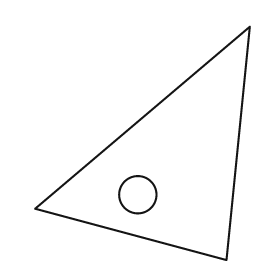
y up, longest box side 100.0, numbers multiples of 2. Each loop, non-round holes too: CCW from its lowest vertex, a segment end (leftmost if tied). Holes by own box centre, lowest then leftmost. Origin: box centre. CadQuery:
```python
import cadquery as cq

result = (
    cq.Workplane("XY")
    .moveTo(36.0, -50.0)
    .lineTo(46.0, 50.0)
    .lineTo(-46.0, -28.0)
    .close()
    .moveTo(-2.0, -22.0)
    .circle(8.0)
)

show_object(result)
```